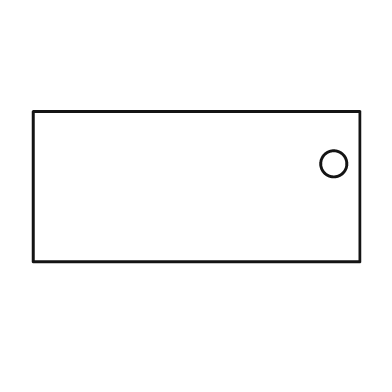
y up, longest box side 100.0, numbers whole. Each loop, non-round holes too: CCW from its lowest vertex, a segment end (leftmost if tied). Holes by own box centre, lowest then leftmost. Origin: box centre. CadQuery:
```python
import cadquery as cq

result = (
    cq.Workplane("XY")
    .moveTo(-50.0, -23.0)
    .lineTo(50.0, -23.0)
    .lineTo(50.0, 23.0)
    .lineTo(-50.0, 23.0)
    .close()
    .moveTo(42.0, 7.0)
    .circle(4.0)
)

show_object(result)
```